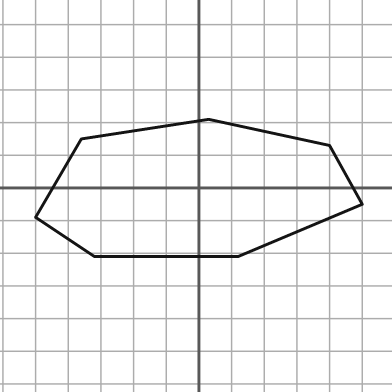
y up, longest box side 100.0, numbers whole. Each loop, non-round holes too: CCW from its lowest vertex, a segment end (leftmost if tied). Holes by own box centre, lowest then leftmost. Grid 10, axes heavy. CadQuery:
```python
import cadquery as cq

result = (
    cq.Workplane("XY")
    .moveTo(-32.0, -21.0)
    .lineTo(12.0, -21.0)
    .lineTo(50.0, -5.0)
    .lineTo(40.0, 13.0)
    .lineTo(3.0, 21.0)
    .lineTo(-36.0, 15.0)
    .lineTo(-50.0, -9.0)
    .close()
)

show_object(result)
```